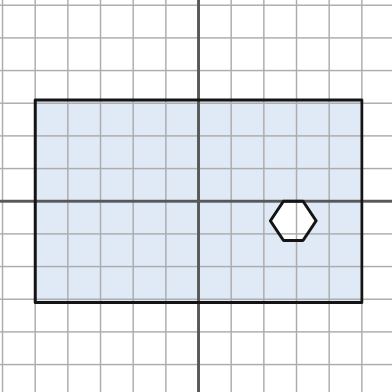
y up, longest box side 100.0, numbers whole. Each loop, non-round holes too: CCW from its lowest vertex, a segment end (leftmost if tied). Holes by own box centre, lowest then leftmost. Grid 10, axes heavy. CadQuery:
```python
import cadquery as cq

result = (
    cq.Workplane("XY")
    .moveTo(-50.0, -31.0)
    .lineTo(50.0, -31.0)
    .lineTo(50.0, 31.0)
    .lineTo(-50.0, 31.0)
    .close()
    .moveTo(26.0, -12.0)
    .lineTo(32.0, -12.0)
    .lineTo(36.0, -6.0)
    .lineTo(32.0, 0.0)
    .lineTo(26.0, 0.0)
    .lineTo(22.0, -6.0)
    .close()
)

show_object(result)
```